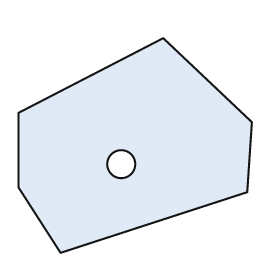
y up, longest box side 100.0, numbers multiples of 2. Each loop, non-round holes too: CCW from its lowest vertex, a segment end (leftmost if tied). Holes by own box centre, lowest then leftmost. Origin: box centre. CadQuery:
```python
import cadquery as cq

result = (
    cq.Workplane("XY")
    .moveTo(-32.0, -46.0)
    .lineTo(48.0, -20.0)
    .lineTo(50.0, 10.0)
    .lineTo(12.0, 46.0)
    .lineTo(-50.0, 14.0)
    .lineTo(-50.0, -18.0)
    .close()
    .moveTo(-6.0, -8.0)
    .circle(6.0)
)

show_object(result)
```